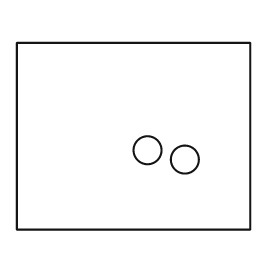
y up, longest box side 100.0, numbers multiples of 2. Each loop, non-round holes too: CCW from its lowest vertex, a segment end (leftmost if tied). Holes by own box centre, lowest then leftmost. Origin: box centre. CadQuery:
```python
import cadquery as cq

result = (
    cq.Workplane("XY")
    .moveTo(-50.0, -40.0)
    .lineTo(50.0, -40.0)
    .lineTo(50.0, 40.0)
    .lineTo(-50.0, 40.0)
    .close()
    .moveTo(22.0, -10.0)
    .circle(6.0)
    .moveTo(6.0, -6.0)
    .circle(6.0)
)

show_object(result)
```